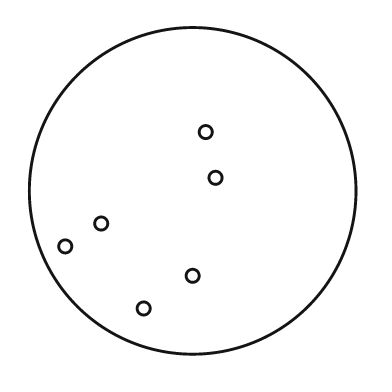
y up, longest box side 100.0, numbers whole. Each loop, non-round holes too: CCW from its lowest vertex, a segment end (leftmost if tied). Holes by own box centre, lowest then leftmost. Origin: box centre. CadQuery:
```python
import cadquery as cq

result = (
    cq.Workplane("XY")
    .moveTo(0.0, 0.0)
    .circle(50.0)
    .moveTo(-15.0, -36.0)
    .circle(2.0)
    .moveTo(0.0, -26.0)
    .circle(2.0)
    .moveTo(-39.0, -17.0)
    .circle(2.0)
    .moveTo(-28.0, -10.0)
    .circle(2.0)
    .moveTo(7.0, 4.0)
    .circle(2.0)
    .moveTo(4.0, 18.0)
    .circle(2.0)
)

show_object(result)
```